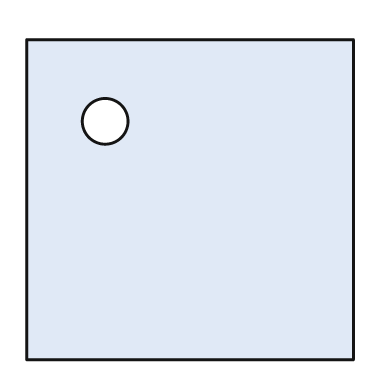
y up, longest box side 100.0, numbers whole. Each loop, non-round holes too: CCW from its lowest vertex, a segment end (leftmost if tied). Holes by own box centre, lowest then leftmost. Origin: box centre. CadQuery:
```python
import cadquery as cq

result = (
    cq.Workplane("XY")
    .moveTo(-50.0, -49.0)
    .lineTo(50.0, -49.0)
    .lineTo(50.0, 49.0)
    .lineTo(-50.0, 49.0)
    .close()
    .moveTo(-26.0, 24.0)
    .circle(7.0)
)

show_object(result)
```